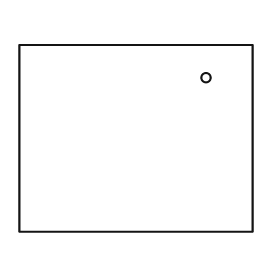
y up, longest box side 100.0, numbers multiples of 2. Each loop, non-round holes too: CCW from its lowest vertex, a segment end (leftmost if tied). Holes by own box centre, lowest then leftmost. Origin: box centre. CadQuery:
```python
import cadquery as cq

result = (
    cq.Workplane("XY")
    .moveTo(-50.0, -40.0)
    .lineTo(50.0, -40.0)
    .lineTo(50.0, 40.0)
    .lineTo(-50.0, 40.0)
    .close()
    .moveTo(30.0, 26.0)
    .circle(2.0)
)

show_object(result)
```